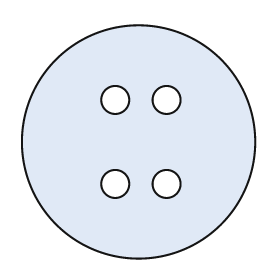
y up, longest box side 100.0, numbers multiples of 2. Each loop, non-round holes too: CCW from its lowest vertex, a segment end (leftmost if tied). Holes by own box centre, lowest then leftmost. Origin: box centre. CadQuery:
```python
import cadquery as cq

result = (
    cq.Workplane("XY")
    .moveTo(0.0, 0.0)
    .circle(50.0)
    .moveTo(-10.0, -18.0)
    .circle(6.0)
    .moveTo(12.0, -18.0)
    .circle(6.0)
    .moveTo(-10.0, 18.0)
    .circle(6.0)
    .moveTo(12.0, 18.0)
    .circle(6.0)
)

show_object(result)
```